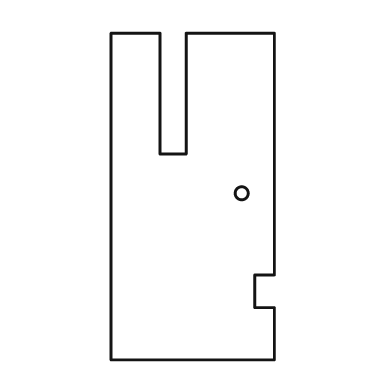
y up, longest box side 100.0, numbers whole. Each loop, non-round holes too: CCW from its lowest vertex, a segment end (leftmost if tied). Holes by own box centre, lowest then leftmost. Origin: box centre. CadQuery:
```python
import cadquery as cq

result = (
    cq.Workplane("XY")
    .moveTo(-25.0, -50.0)
    .lineTo(25.0, -50.0)
    .lineTo(25.0, -34.0)
    .lineTo(19.0, -34.0)
    .lineTo(19.0, -24.0)
    .lineTo(25.0, -24.0)
    .lineTo(25.0, 50.0)
    .lineTo(-2.0, 50.0)
    .lineTo(-2.0, 13.0)
    .lineTo(-10.0, 13.0)
    .lineTo(-10.0, 50.0)
    .lineTo(-25.0, 50.0)
    .close()
    .moveTo(15.0, 1.0)
    .circle(2.0)
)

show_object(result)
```